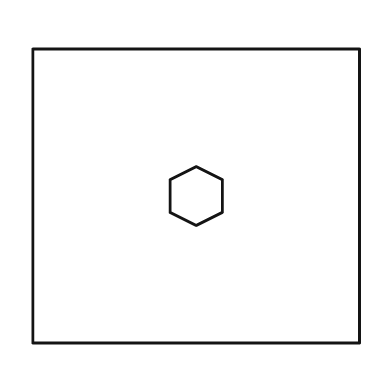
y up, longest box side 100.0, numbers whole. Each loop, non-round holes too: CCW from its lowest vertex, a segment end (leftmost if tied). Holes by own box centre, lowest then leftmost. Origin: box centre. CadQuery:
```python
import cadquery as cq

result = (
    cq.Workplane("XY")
    .moveTo(-50.0, -45.0)
    .lineTo(50.0, -45.0)
    .lineTo(50.0, 45.0)
    .lineTo(-50.0, 45.0)
    .close()
    .moveTo(0.0, -9.0)
    .lineTo(8.0, -5.0)
    .lineTo(8.0, 5.0)
    .lineTo(0.0, 9.0)
    .lineTo(-8.0, 5.0)
    .lineTo(-8.0, -5.0)
    .close()
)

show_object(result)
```